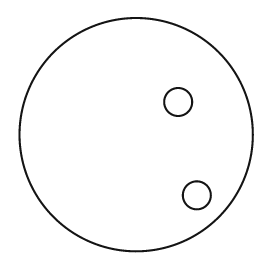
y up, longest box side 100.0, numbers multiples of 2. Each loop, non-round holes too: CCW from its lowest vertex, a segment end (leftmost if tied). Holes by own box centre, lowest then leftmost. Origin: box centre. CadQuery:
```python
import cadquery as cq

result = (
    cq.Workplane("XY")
    .moveTo(0.0, 0.0)
    .circle(50.0)
    .moveTo(26.0, -26.0)
    .circle(6.0)
    .moveTo(18.0, 14.0)
    .circle(6.0)
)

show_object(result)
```